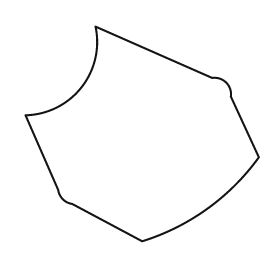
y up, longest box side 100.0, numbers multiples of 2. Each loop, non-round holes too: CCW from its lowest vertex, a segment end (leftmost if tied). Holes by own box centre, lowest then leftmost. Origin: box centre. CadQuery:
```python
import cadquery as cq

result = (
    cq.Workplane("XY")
    .moveTo(0.0, -46.0)
    .threePointArc((28.0, -32.0), (50.0, -10.0))
    .lineTo(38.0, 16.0)
    .threePointArc((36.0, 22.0), (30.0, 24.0))
    .lineTo(-20.0, 46.0)
    .threePointArc((-26.0, 20.0), (-50.0, 8.0))
    .lineTo(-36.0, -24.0)
    .threePointArc((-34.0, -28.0), (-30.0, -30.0))
    .close()
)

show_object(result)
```